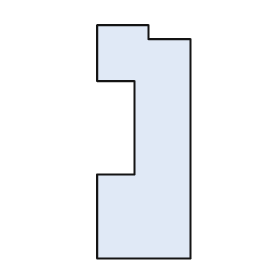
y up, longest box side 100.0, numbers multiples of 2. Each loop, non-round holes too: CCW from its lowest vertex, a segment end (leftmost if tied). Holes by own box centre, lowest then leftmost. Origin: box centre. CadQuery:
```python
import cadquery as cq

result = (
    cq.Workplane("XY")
    .moveTo(-20.0, -50.0)
    .lineTo(20.0, -50.0)
    .lineTo(20.0, 44.0)
    .lineTo(2.0, 44.0)
    .lineTo(2.0, 50.0)
    .lineTo(-20.0, 50.0)
    .lineTo(-20.0, 26.0)
    .lineTo(-4.0, 26.0)
    .lineTo(-4.0, -14.0)
    .lineTo(-20.0, -14.0)
    .close()
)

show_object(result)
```